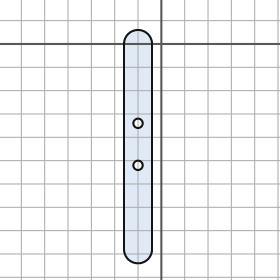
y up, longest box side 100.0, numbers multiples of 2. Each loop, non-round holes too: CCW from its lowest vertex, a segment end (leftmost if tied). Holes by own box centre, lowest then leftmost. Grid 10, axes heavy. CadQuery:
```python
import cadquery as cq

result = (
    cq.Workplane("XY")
    .moveTo(-16.0, -88.0)
    .threePointArc((-10.0, -94.0), (-4.0, -88.0))
    .lineTo(-4.0, 0.0)
    .threePointArc((-10.0, 6.0), (-16.0, 0.0))
    .close()
    .moveTo(-10.0, -52.0)
    .circle(2.0)
    .moveTo(-10.0, -34.0)
    .circle(2.0)
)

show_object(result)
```